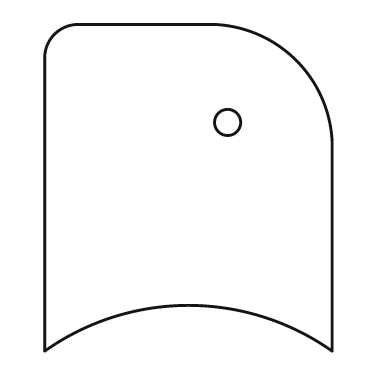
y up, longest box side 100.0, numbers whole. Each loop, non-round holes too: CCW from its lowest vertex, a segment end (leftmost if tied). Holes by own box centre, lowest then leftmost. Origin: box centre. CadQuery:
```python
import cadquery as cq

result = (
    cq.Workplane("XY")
    .moveTo(-44.0, -50.0)
    .threePointArc((0.0, -36.0), (44.0, -50.0))
    .lineTo(44.0, 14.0)
    .threePointArc((33.0, 39.0), (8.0, 50.0))
    .lineTo(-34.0, 50.0)
    .threePointArc((-41.0, 47.0), (-44.0, 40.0))
    .close()
    .moveTo(12.0, 20.0)
    .circle(4.0)
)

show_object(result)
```